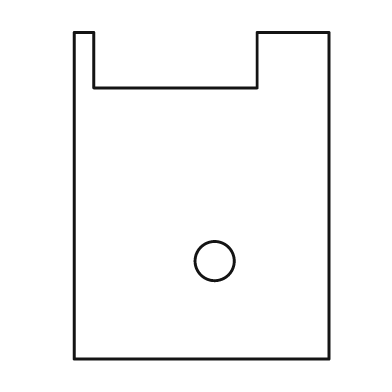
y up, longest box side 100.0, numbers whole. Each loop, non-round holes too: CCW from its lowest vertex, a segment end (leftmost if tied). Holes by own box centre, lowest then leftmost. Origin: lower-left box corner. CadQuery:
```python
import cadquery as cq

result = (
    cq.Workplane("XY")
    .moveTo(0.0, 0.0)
    .lineTo(78.0, 0.0)
    .lineTo(78.0, 100.0)
    .lineTo(56.0, 100.0)
    .lineTo(56.0, 83.0)
    .lineTo(6.0, 83.0)
    .lineTo(6.0, 100.0)
    .lineTo(0.0, 100.0)
    .close()
    .moveTo(43.0, 30.0)
    .circle(6.0)
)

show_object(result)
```